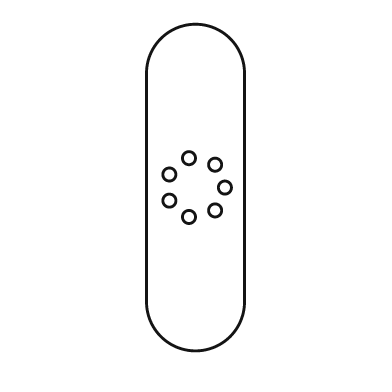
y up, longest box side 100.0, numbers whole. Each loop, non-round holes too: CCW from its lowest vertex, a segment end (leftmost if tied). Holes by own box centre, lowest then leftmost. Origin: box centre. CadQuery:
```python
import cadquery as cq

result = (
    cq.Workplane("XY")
    .moveTo(-15.0, -35.0)
    .threePointArc((0.0, -50.0), (15.0, -35.0))
    .lineTo(15.0, 35.0)
    .threePointArc((0.0, 50.0), (-15.0, 35.0))
    .close()
    .moveTo(-2.0, -9.0)
    .circle(2.0)
    .moveTo(6.0, -7.0)
    .circle(2.0)
    .moveTo(-8.0, -4.0)
    .circle(2.0)
    .moveTo(9.0, 0.0)
    .circle(2.0)
    .moveTo(-8.0, 4.0)
    .circle(2.0)
    .moveTo(6.0, 7.0)
    .circle(2.0)
    .moveTo(-2.0, 9.0)
    .circle(2.0)
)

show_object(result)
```